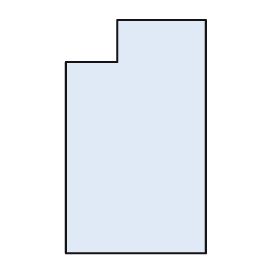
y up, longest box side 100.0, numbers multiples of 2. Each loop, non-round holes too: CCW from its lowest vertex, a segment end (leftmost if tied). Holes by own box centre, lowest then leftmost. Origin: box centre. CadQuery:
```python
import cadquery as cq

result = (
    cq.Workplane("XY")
    .moveTo(-30.0, -50.0)
    .lineTo(30.0, -50.0)
    .lineTo(30.0, 50.0)
    .lineTo(-8.0, 50.0)
    .lineTo(-8.0, 32.0)
    .lineTo(-30.0, 32.0)
    .close()
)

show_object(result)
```